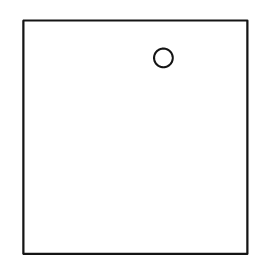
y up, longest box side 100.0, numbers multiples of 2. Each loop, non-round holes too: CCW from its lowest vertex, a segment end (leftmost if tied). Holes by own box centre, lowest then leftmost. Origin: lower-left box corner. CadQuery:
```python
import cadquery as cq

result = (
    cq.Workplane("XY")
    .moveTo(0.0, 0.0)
    .lineTo(96.0, 0.0)
    .lineTo(96.0, 100.0)
    .lineTo(0.0, 100.0)
    .close()
    .moveTo(60.0, 84.0)
    .circle(4.0)
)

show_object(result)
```